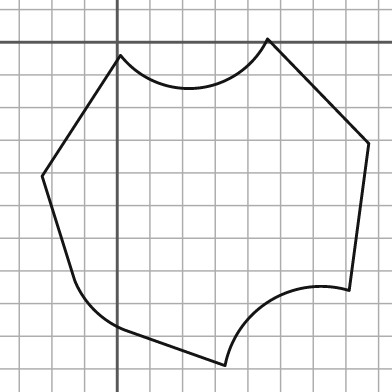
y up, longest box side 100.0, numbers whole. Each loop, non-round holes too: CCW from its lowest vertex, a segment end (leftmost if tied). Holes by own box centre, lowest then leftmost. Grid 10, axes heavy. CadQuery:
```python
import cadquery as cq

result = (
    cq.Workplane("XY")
    .moveTo(33.0, -99.0)
    .threePointArc((47.0, -79.0), (71.0, -76.0))
    .lineTo(77.0, -31.0)
    .lineTo(46.0, 1.0)
    .threePointArc((25.0, -14.0), (1.0, -4.0))
    .lineTo(-23.0, -41.0)
    .lineTo(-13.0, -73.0)
    .threePointArc((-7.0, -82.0), (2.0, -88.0))
    .close()
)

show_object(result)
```